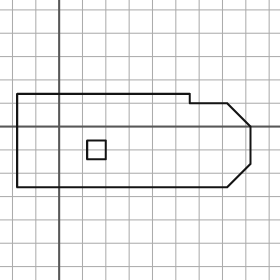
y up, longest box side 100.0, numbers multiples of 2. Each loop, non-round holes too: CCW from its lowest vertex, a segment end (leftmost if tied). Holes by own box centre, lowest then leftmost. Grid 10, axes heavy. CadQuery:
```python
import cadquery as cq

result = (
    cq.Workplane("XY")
    .moveTo(-18.0, -26.0)
    .lineTo(72.0, -26.0)
    .lineTo(82.0, -16.0)
    .lineTo(82.0, 0.0)
    .lineTo(72.0, 10.0)
    .lineTo(56.0, 10.0)
    .lineTo(56.0, 14.0)
    .lineTo(-18.0, 14.0)
    .close()
    .moveTo(12.0, -14.0)
    .lineTo(20.0, -14.0)
    .lineTo(20.0, -6.0)
    .lineTo(12.0, -6.0)
    .close()
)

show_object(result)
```